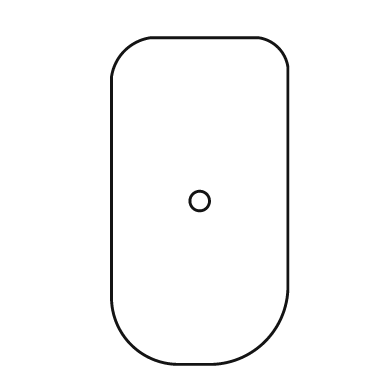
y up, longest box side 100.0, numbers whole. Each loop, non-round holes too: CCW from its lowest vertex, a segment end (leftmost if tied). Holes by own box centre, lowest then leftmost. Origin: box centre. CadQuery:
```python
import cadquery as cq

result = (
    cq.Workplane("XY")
    .moveTo(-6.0, -50.0)
    .lineTo(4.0, -50.0)
    .threePointArc((20.0, -43.0), (27.0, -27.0))
    .lineTo(27.0, 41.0)
    .threePointArc((24.0, 47.0), (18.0, 50.0))
    .lineTo(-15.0, 50.0)
    .threePointArc((-23.0, 46.0), (-27.0, 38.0))
    .lineTo(-27.0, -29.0)
    .threePointArc((-21.0, -44.0), (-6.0, -50.0))
    .close()
    .moveTo(0.0, 0.0)
    .circle(3.0)
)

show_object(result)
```